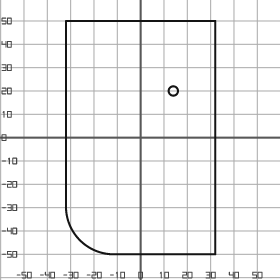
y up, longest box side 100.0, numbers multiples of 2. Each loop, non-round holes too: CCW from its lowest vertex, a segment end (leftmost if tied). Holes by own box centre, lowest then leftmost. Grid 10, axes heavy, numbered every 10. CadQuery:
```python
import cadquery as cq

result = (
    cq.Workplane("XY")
    .moveTo(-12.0, -50.0)
    .lineTo(32.0, -50.0)
    .lineTo(32.0, 50.0)
    .lineTo(-32.0, 50.0)
    .lineTo(-32.0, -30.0)
    .threePointArc((-26.0, -44.0), (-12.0, -50.0))
    .close()
    .moveTo(14.0, 20.0)
    .circle(2.0)
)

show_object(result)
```